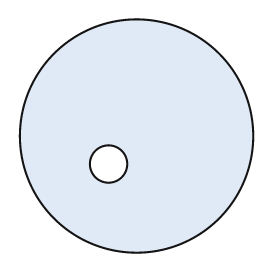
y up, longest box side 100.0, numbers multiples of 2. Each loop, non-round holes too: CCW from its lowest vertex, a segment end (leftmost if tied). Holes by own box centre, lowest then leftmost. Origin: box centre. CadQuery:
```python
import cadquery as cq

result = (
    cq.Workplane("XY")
    .moveTo(0.0, 0.0)
    .circle(50.0)
    .moveTo(-12.0, -12.0)
    .circle(8.0)
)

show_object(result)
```